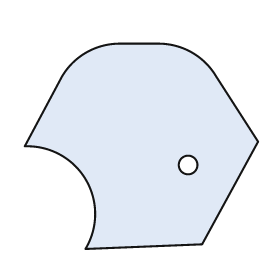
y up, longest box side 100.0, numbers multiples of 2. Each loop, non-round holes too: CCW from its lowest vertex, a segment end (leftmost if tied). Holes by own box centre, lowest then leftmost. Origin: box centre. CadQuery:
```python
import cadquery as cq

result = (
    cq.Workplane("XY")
    .moveTo(-24.0, -44.0)
    .lineTo(26.0, -42.0)
    .lineTo(50.0, 2.0)
    .lineTo(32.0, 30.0)
    .threePointArc((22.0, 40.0), (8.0, 44.0))
    .lineTo(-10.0, 44.0)
    .threePointArc((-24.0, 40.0), (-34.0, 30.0))
    .lineTo(-50.0, 0.0)
    .threePointArc((-24.0, -14.0), (-24.0, -44.0))
    .close()
    .moveTo(20.0, -8.0)
    .circle(4.0)
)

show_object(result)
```